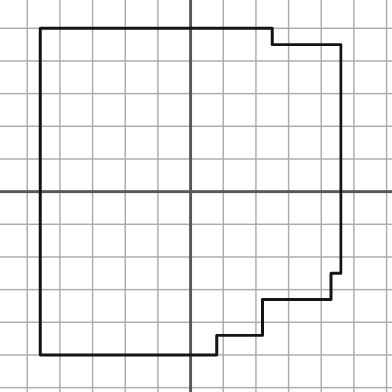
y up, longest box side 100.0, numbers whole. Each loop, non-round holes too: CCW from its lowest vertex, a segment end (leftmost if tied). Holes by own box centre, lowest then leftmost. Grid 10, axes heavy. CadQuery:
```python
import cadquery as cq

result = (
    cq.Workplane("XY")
    .moveTo(-46.0, -50.0)
    .lineTo(8.0, -50.0)
    .lineTo(8.0, -44.0)
    .lineTo(22.0, -44.0)
    .lineTo(22.0, -33.0)
    .lineTo(43.0, -33.0)
    .lineTo(43.0, -25.0)
    .lineTo(46.0, -25.0)
    .lineTo(46.0, 45.0)
    .lineTo(25.0, 45.0)
    .lineTo(25.0, 50.0)
    .lineTo(-46.0, 50.0)
    .close()
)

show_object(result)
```